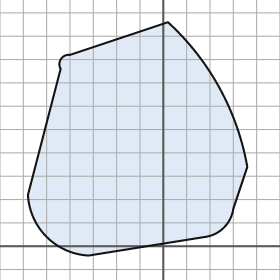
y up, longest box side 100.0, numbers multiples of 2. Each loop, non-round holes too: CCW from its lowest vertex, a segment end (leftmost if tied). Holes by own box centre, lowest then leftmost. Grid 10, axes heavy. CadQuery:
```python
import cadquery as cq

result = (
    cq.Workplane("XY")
    .moveTo(-32.0, -4.0)
    .lineTo(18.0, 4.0)
    .threePointArc((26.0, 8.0), (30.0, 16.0))
    .lineTo(36.0, 34.0)
    .threePointArc((24.0, 68.0), (2.0, 96.0))
    .lineTo(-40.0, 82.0)
    .threePointArc((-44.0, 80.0), (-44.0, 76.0))
    .lineTo(-58.0, 22.0)
    .threePointArc((-50.0, 4.0), (-32.0, -4.0))
    .close()
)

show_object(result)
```